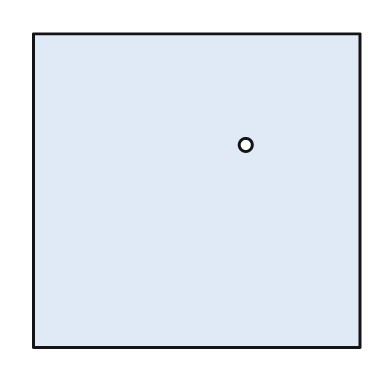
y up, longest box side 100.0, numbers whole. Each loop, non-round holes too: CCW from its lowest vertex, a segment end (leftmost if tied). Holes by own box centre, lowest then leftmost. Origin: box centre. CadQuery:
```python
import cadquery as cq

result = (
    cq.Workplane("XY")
    .moveTo(-50.0, -48.0)
    .lineTo(50.0, -48.0)
    .lineTo(50.0, 48.0)
    .lineTo(-50.0, 48.0)
    .close()
    .moveTo(15.0, 14.0)
    .circle(2.0)
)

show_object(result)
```